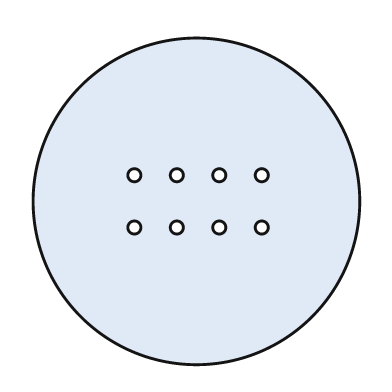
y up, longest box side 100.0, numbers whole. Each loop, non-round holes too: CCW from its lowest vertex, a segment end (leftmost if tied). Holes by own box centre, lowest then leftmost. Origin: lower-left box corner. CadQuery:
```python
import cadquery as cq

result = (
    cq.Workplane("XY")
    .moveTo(50.0, 50.0)
    .circle(50.0)
    .moveTo(31.0, 42.0)
    .circle(2.0)
    .moveTo(44.0, 42.0)
    .circle(2.0)
    .moveTo(57.0, 42.0)
    .circle(2.0)
    .moveTo(70.0, 42.0)
    .circle(2.0)
    .moveTo(31.0, 58.0)
    .circle(2.0)
    .moveTo(44.0, 58.0)
    .circle(2.0)
    .moveTo(57.0, 58.0)
    .circle(2.0)
    .moveTo(70.0, 58.0)
    .circle(2.0)
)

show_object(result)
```